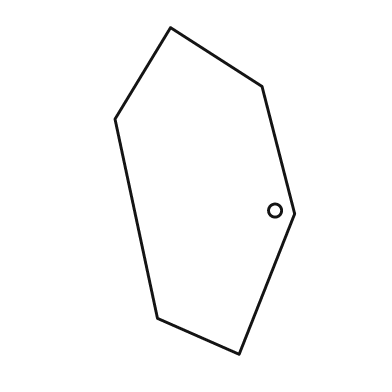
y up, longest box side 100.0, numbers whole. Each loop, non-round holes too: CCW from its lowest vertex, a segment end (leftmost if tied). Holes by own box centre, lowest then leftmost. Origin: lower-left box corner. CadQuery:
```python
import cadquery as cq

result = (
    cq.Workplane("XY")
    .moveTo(38.0, 0.0)
    .lineTo(55.0, 43.0)
    .lineTo(45.0, 82.0)
    .lineTo(17.0, 100.0)
    .lineTo(0.0, 72.0)
    .lineTo(13.0, 11.0)
    .close()
    .moveTo(49.0, 44.0)
    .circle(2.0)
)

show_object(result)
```